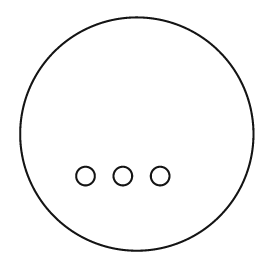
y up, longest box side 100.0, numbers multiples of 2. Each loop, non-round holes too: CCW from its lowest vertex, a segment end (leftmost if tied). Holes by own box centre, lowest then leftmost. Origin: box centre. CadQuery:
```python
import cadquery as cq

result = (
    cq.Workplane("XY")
    .moveTo(0.0, 0.0)
    .circle(50.0)
    .moveTo(-22.0, -18.0)
    .circle(4.0)
    .moveTo(-6.0, -18.0)
    .circle(4.0)
    .moveTo(10.0, -18.0)
    .circle(4.0)
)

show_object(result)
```